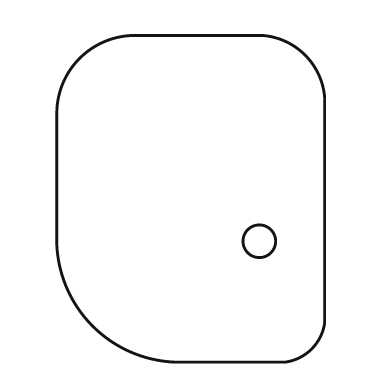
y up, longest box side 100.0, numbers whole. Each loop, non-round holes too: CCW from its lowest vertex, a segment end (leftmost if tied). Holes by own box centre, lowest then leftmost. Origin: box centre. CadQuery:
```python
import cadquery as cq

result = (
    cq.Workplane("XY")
    .moveTo(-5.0, -50.0)
    .lineTo(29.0, -50.0)
    .threePointArc((37.0, -46.0), (41.0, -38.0))
    .lineTo(41.0, 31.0)
    .threePointArc((35.0, 44.0), (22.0, 50.0))
    .lineTo(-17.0, 50.0)
    .threePointArc((-34.0, 43.0), (-41.0, 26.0))
    .lineTo(-41.0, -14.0)
    .threePointArc((-30.0, -39.0), (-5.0, -50.0))
    .close()
    .moveTo(21.0, -13.0)
    .circle(5.0)
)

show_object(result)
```